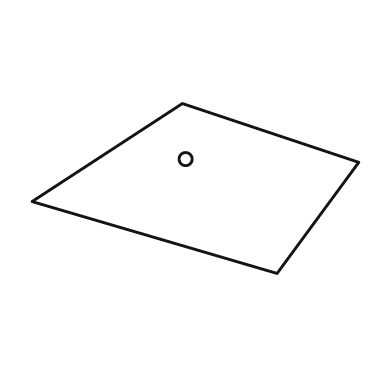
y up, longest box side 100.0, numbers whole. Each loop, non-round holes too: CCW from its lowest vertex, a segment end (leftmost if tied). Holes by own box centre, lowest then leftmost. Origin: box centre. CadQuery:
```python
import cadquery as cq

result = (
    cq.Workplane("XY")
    .moveTo(25.0, -26.0)
    .lineTo(50.0, 8.0)
    .lineTo(-4.0, 26.0)
    .lineTo(-50.0, -4.0)
    .close()
    .moveTo(-3.0, 9.0)
    .circle(2.0)
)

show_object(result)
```